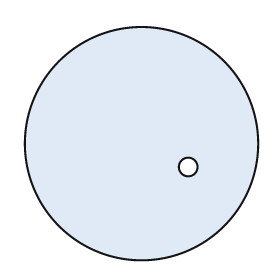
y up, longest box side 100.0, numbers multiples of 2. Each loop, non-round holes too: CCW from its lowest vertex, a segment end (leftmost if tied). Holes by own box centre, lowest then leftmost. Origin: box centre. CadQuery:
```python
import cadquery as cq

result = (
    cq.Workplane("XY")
    .moveTo(0.0, 0.0)
    .circle(50.0)
    .moveTo(20.0, -10.0)
    .circle(4.0)
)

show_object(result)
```